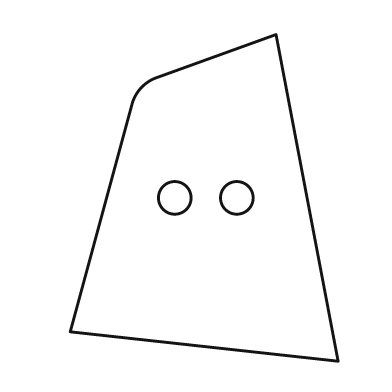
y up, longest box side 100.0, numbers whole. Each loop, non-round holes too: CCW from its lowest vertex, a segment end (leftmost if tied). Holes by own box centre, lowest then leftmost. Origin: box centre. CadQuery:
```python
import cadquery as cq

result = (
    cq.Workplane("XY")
    .moveTo(41.0, -50.0)
    .lineTo(22.0, 50.0)
    .lineTo(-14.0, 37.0)
    .threePointArc((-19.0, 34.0), (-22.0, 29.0))
    .lineTo(-41.0, -41.0)
    .close()
    .moveTo(-9.0, 0.0)
    .circle(5.0)
    .moveTo(10.0, 0.0)
    .circle(5.0)
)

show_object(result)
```